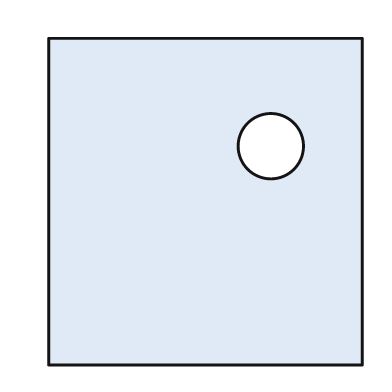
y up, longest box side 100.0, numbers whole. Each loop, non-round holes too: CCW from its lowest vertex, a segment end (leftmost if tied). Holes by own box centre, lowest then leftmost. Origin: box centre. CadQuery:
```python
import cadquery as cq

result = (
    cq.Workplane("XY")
    .moveTo(-48.0, -50.0)
    .lineTo(48.0, -50.0)
    .lineTo(48.0, 50.0)
    .lineTo(-48.0, 50.0)
    .close()
    .moveTo(20.0, 17.0)
    .circle(10.0)
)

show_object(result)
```